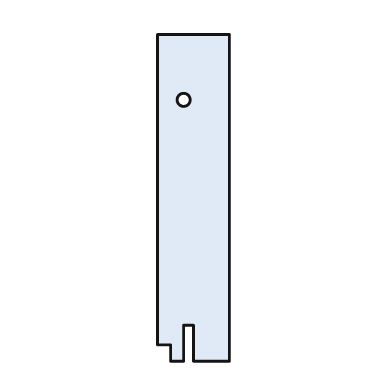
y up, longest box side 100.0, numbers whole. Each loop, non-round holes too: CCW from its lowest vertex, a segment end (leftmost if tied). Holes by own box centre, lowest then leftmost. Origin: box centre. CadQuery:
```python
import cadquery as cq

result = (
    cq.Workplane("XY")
    .moveTo(-7.0, -50.0)
    .lineTo(-3.0, -50.0)
    .lineTo(-3.0, -39.0)
    .lineTo(0.0, -39.0)
    .lineTo(0.0, -50.0)
    .lineTo(11.0, -50.0)
    .lineTo(11.0, 50.0)
    .lineTo(-11.0, 50.0)
    .lineTo(-11.0, -45.0)
    .lineTo(-7.0, -45.0)
    .close()
    .moveTo(-3.0, 30.0)
    .circle(2.0)
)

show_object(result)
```